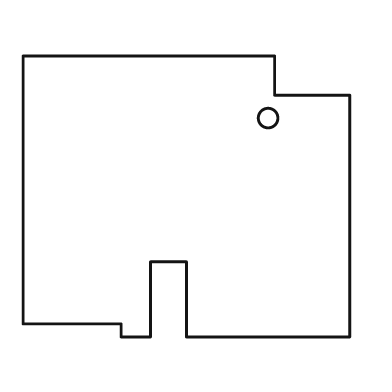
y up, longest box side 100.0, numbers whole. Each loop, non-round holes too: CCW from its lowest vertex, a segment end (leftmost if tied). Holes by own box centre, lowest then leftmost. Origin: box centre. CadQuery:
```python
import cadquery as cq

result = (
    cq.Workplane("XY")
    .moveTo(-20.0, -43.0)
    .lineTo(-11.0, -43.0)
    .lineTo(-11.0, -20.0)
    .lineTo(0.0, -20.0)
    .lineTo(0.0, -43.0)
    .lineTo(50.0, -43.0)
    .lineTo(50.0, 31.0)
    .lineTo(27.0, 31.0)
    .lineTo(27.0, 43.0)
    .lineTo(-50.0, 43.0)
    .lineTo(-50.0, -39.0)
    .lineTo(-20.0, -39.0)
    .close()
    .moveTo(25.0, 24.0)
    .circle(3.0)
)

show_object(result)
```